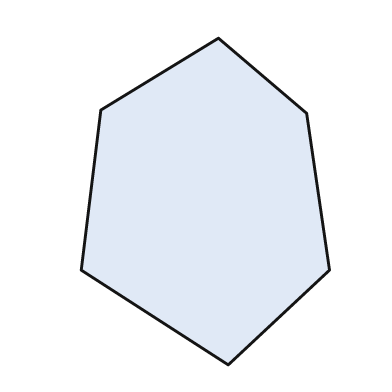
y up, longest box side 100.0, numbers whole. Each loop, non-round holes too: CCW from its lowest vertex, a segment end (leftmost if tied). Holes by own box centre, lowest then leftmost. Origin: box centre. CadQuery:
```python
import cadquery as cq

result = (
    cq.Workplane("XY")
    .moveTo(7.0, -50.0)
    .lineTo(38.0, -21.0)
    .lineTo(31.0, 27.0)
    .lineTo(4.0, 50.0)
    .lineTo(-32.0, 28.0)
    .lineTo(-38.0, -21.0)
    .close()
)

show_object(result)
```